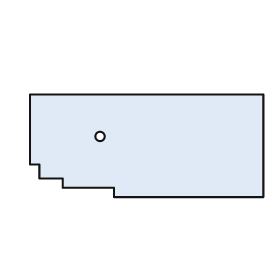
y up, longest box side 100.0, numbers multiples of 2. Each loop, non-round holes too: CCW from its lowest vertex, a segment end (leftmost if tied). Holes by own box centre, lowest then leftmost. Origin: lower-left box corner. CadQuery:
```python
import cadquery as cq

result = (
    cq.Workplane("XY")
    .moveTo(36.0, 0.0)
    .lineTo(100.0, 0.0)
    .lineTo(100.0, 44.0)
    .lineTo(0.0, 44.0)
    .lineTo(0.0, 14.0)
    .lineTo(4.0, 14.0)
    .lineTo(4.0, 8.0)
    .lineTo(14.0, 8.0)
    .lineTo(14.0, 4.0)
    .lineTo(36.0, 4.0)
    .close()
    .moveTo(30.0, 26.0)
    .circle(2.0)
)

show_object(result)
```